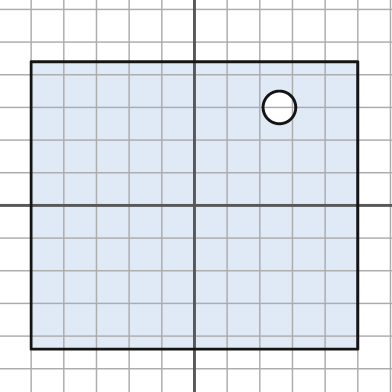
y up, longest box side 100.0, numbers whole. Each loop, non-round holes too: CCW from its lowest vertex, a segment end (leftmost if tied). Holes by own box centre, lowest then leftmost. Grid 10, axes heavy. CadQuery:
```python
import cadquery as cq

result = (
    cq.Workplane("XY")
    .moveTo(-50.0, -44.0)
    .lineTo(50.0, -44.0)
    .lineTo(50.0, 44.0)
    .lineTo(-50.0, 44.0)
    .close()
    .moveTo(26.0, 30.0)
    .circle(5.0)
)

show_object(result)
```